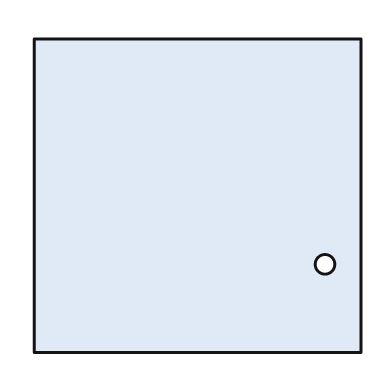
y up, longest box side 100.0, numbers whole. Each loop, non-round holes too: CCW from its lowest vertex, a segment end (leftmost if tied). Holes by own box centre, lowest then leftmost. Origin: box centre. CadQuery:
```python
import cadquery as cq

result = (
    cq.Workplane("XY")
    .moveTo(-50.0, -48.0)
    .lineTo(50.0, -48.0)
    .lineTo(50.0, 48.0)
    .lineTo(-50.0, 48.0)
    .close()
    .moveTo(39.0, -21.0)
    .circle(3.0)
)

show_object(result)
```